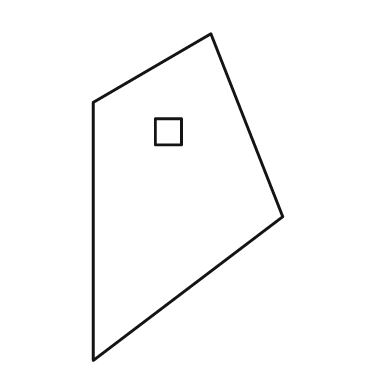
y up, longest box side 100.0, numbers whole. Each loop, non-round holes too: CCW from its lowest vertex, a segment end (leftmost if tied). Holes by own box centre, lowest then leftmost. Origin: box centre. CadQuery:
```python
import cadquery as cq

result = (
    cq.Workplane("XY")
    .moveTo(-29.0, -50.0)
    .lineTo(29.0, -6.0)
    .lineTo(7.0, 50.0)
    .lineTo(-29.0, 29.0)
    .close()
    .moveTo(-10.0, 16.0)
    .lineTo(-2.0, 16.0)
    .lineTo(-2.0, 24.0)
    .lineTo(-10.0, 24.0)
    .close()
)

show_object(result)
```